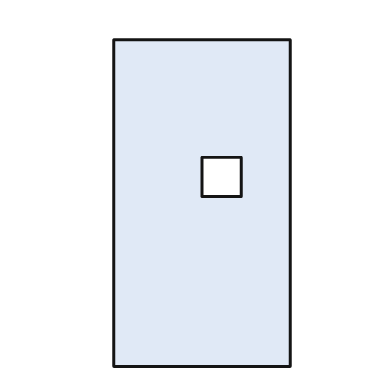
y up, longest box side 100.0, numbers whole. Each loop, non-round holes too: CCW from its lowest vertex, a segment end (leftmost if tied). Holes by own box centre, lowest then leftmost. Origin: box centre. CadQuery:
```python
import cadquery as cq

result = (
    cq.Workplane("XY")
    .moveTo(-27.0, -50.0)
    .lineTo(27.0, -50.0)
    .lineTo(27.0, 50.0)
    .lineTo(-27.0, 50.0)
    .close()
    .moveTo(0.0, 2.0)
    .lineTo(12.0, 2.0)
    .lineTo(12.0, 14.0)
    .lineTo(0.0, 14.0)
    .close()
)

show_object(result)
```